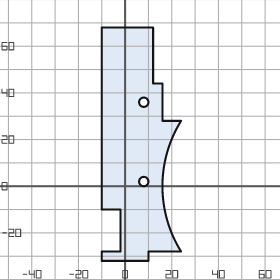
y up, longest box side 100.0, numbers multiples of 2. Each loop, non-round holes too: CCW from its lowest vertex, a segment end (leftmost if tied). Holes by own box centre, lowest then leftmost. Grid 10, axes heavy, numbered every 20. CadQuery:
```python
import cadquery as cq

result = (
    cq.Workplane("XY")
    .moveTo(-10.0, -32.0)
    .lineTo(10.0, -32.0)
    .lineTo(10.0, -28.0)
    .lineTo(24.0, -28.0)
    .threePointArc((16.0, 0.0), (24.0, 28.0))
    .lineTo(16.0, 28.0)
    .lineTo(16.0, 44.0)
    .lineTo(12.0, 44.0)
    .lineTo(12.0, 68.0)
    .lineTo(-10.0, 68.0)
    .lineTo(-10.0, -10.0)
    .lineTo(-2.0, -10.0)
    .lineTo(-2.0, -28.0)
    .lineTo(-10.0, -28.0)
    .close()
    .moveTo(8.0, 2.0)
    .circle(2.0)
    .moveTo(8.0, 36.0)
    .circle(2.0)
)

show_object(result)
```